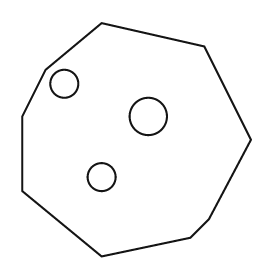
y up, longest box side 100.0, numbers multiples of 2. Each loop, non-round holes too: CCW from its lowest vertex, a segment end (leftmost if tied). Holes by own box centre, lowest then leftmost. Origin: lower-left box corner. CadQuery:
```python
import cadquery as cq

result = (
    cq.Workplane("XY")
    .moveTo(34.0, 0.0)
    .lineTo(72.0, 8.0)
    .lineTo(80.0, 16.0)
    .lineTo(98.0, 50.0)
    .lineTo(78.0, 90.0)
    .lineTo(34.0, 100.0)
    .lineTo(10.0, 80.0)
    .lineTo(0.0, 60.0)
    .lineTo(0.0, 28.0)
    .close()
    .moveTo(34.0, 34.0)
    .circle(6.0)
    .moveTo(54.0, 60.0)
    .circle(8.0)
    .moveTo(18.0, 74.0)
    .circle(6.0)
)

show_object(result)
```